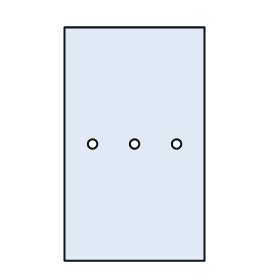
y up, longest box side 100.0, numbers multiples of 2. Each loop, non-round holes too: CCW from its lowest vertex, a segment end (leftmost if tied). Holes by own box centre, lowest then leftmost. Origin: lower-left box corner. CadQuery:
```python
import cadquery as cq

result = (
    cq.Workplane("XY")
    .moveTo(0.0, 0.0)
    .lineTo(60.0, 0.0)
    .lineTo(60.0, 100.0)
    .lineTo(0.0, 100.0)
    .close()
    .moveTo(12.0, 50.0)
    .circle(2.0)
    .moveTo(30.0, 50.0)
    .circle(2.0)
    .moveTo(48.0, 50.0)
    .circle(2.0)
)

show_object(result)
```